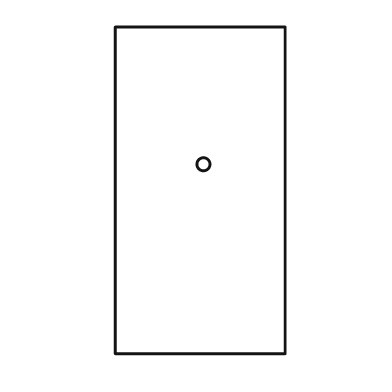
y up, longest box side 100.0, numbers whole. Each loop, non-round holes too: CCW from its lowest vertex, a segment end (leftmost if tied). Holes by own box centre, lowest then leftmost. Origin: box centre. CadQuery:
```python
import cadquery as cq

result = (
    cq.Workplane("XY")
    .moveTo(-26.0, -50.0)
    .lineTo(26.0, -50.0)
    .lineTo(26.0, 50.0)
    .lineTo(-26.0, 50.0)
    .close()
    .moveTo(1.0, 8.0)
    .circle(2.0)
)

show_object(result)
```